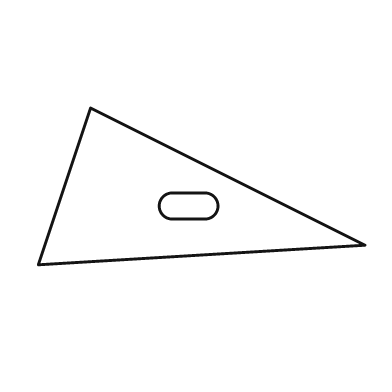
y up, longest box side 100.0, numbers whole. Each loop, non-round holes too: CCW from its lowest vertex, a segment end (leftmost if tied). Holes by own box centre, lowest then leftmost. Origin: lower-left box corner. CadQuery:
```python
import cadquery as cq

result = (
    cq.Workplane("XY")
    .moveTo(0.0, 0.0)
    .lineTo(100.0, 6.0)
    .lineTo(16.0, 48.0)
    .close()
    .moveTo(41.0, 14.0)
    .lineTo(51.0, 14.0)
    .threePointArc((55.0, 18.0), (51.0, 22.0))
    .lineTo(41.0, 22.0)
    .threePointArc((37.0, 18.0), (41.0, 14.0))
    .close()
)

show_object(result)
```